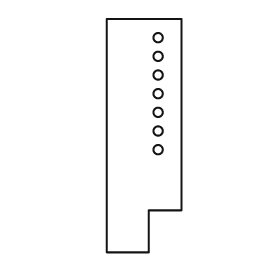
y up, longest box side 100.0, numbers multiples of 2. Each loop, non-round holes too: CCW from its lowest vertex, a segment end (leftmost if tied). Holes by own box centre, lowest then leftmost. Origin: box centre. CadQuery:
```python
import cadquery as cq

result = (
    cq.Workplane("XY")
    .moveTo(-16.0, -50.0)
    .lineTo(2.0, -50.0)
    .lineTo(2.0, -32.0)
    .lineTo(16.0, -32.0)
    .lineTo(16.0, 50.0)
    .lineTo(-16.0, 50.0)
    .close()
    .moveTo(6.0, -6.0)
    .circle(2.0)
    .moveTo(6.0, 2.0)
    .circle(2.0)
    .moveTo(6.0, 10.0)
    .circle(2.0)
    .moveTo(6.0, 18.0)
    .circle(2.0)
    .moveTo(6.0, 26.0)
    .circle(2.0)
    .moveTo(6.0, 34.0)
    .circle(2.0)
    .moveTo(6.0, 42.0)
    .circle(2.0)
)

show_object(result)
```